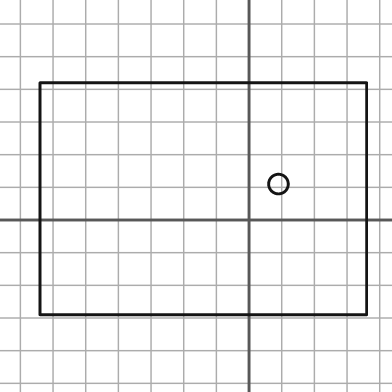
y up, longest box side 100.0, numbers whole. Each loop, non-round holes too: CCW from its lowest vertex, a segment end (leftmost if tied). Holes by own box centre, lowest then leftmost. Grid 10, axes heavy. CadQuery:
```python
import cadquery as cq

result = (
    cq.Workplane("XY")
    .moveTo(-64.0, -29.0)
    .lineTo(36.0, -29.0)
    .lineTo(36.0, 42.0)
    .lineTo(-64.0, 42.0)
    .close()
    .moveTo(9.0, 11.0)
    .circle(3.0)
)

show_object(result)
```